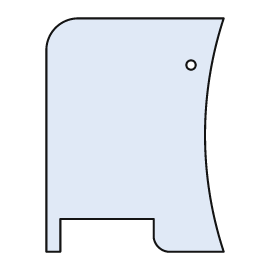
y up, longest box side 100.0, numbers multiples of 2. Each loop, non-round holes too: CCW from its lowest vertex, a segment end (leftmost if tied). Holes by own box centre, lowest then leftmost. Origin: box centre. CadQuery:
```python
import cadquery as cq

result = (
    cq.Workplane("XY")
    .moveTo(-38.0, -50.0)
    .lineTo(-32.0, -50.0)
    .lineTo(-32.0, -36.0)
    .lineTo(8.0, -36.0)
    .lineTo(8.0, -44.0)
    .threePointArc((10.0, -48.0), (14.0, -50.0))
    .lineTo(38.0, -50.0)
    .threePointArc((30.0, 0.0), (38.0, 50.0))
    .lineTo(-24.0, 50.0)
    .threePointArc((-34.0, 46.0), (-38.0, 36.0))
    .close()
    .moveTo(24.0, 30.0)
    .circle(2.0)
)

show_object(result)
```